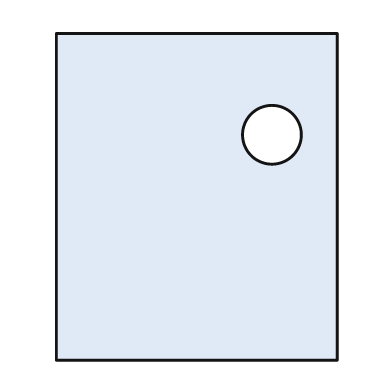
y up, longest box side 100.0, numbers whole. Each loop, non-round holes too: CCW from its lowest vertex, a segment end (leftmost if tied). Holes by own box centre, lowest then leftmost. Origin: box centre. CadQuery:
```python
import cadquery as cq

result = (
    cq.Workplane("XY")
    .moveTo(-43.0, -50.0)
    .lineTo(43.0, -50.0)
    .lineTo(43.0, 50.0)
    .lineTo(-43.0, 50.0)
    .close()
    .moveTo(23.0, 19.0)
    .circle(9.0)
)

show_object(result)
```